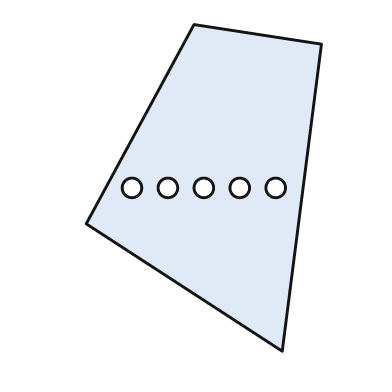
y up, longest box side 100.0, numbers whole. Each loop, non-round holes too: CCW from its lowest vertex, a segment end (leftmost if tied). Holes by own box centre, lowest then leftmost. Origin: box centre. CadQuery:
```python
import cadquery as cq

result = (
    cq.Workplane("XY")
    .moveTo(24.0, -50.0)
    .lineTo(36.0, 44.0)
    .lineTo(-3.0, 50.0)
    .lineTo(-36.0, -11.0)
    .close()
    .moveTo(-22.0, 0.0)
    .circle(3.0)
    .moveTo(-11.0, 0.0)
    .circle(3.0)
    .moveTo(0.0, 0.0)
    .circle(3.0)
    .moveTo(11.0, 0.0)
    .circle(3.0)
    .moveTo(22.0, 0.0)
    .circle(3.0)
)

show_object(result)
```